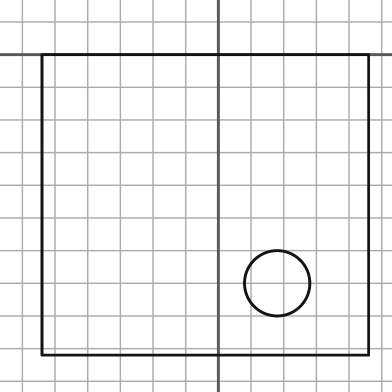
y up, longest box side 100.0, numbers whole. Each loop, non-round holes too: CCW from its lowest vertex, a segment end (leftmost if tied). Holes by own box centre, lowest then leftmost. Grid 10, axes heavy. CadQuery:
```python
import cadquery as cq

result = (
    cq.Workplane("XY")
    .moveTo(-54.0, -92.0)
    .lineTo(46.0, -92.0)
    .lineTo(46.0, 0.0)
    .lineTo(-54.0, 0.0)
    .close()
    .moveTo(18.0, -70.0)
    .circle(10.0)
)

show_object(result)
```